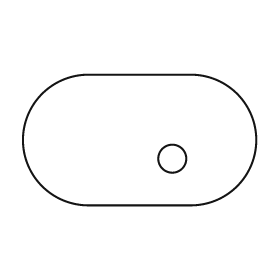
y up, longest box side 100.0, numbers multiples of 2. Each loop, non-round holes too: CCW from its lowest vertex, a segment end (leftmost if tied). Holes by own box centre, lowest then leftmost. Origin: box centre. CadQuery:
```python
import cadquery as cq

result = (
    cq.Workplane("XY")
    .moveTo(-22.0, -28.0)
    .lineTo(22.0, -28.0)
    .threePointArc((50.0, 0.0), (22.0, 28.0))
    .lineTo(-22.0, 28.0)
    .threePointArc((-50.0, 0.0), (-22.0, -28.0))
    .close()
    .moveTo(14.0, -8.0)
    .circle(6.0)
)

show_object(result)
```